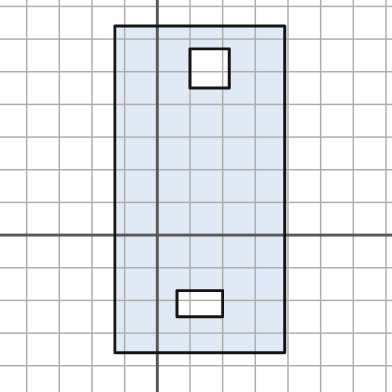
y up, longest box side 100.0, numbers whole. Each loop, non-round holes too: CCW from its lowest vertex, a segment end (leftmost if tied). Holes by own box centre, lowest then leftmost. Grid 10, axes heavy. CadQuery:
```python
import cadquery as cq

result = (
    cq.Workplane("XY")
    .moveTo(-13.0, -36.0)
    .lineTo(39.0, -36.0)
    .lineTo(39.0, 64.0)
    .lineTo(-13.0, 64.0)
    .close()
    .moveTo(6.0, -25.0)
    .lineTo(20.0, -25.0)
    .lineTo(20.0, -17.0)
    .lineTo(6.0, -17.0)
    .close()
    .moveTo(10.0, 45.0)
    .lineTo(22.0, 45.0)
    .lineTo(22.0, 57.0)
    .lineTo(10.0, 57.0)
    .close()
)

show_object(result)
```